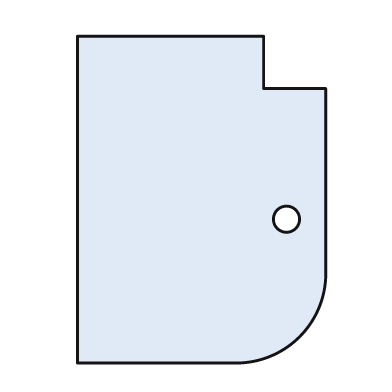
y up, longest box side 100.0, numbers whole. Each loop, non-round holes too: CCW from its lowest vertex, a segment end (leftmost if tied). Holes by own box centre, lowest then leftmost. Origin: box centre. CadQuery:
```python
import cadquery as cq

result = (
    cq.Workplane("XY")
    .moveTo(-38.0, -50.0)
    .lineTo(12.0, -50.0)
    .threePointArc((30.0, -42.0), (38.0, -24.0))
    .lineTo(38.0, 34.0)
    .lineTo(19.0, 34.0)
    .lineTo(19.0, 50.0)
    .lineTo(-38.0, 50.0)
    .close()
    .moveTo(26.0, -6.0)
    .circle(4.0)
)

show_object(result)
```